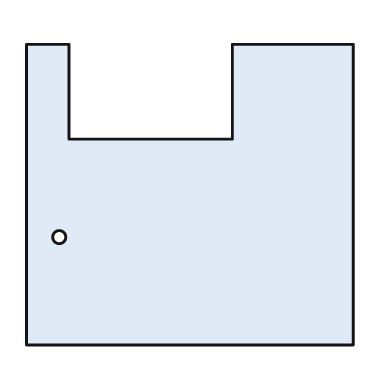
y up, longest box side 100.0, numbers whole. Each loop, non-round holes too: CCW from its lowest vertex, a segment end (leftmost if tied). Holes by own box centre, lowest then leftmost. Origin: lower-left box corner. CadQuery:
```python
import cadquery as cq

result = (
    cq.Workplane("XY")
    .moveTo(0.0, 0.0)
    .lineTo(100.0, 0.0)
    .lineTo(100.0, 92.0)
    .lineTo(63.0, 92.0)
    .lineTo(63.0, 63.0)
    .lineTo(13.0, 63.0)
    .lineTo(13.0, 92.0)
    .lineTo(0.0, 92.0)
    .close()
    .moveTo(10.0, 33.0)
    .circle(2.0)
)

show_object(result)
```